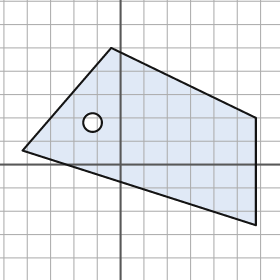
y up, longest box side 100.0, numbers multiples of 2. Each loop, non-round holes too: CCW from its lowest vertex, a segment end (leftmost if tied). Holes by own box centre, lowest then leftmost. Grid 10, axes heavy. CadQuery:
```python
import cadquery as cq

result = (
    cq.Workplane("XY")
    .moveTo(58.0, -26.0)
    .lineTo(58.0, 20.0)
    .lineTo(-4.0, 50.0)
    .lineTo(-42.0, 6.0)
    .close()
    .moveTo(-12.0, 18.0)
    .circle(4.0)
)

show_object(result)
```